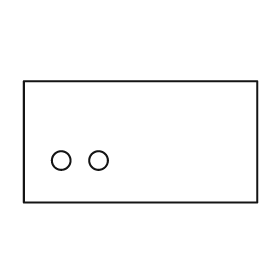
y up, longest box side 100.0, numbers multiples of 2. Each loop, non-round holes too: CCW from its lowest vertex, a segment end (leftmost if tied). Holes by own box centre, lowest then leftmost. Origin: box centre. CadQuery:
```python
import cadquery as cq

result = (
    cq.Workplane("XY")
    .moveTo(-50.0, -26.0)
    .lineTo(50.0, -26.0)
    .lineTo(50.0, 26.0)
    .lineTo(-50.0, 26.0)
    .close()
    .moveTo(-34.0, -8.0)
    .circle(4.0)
    .moveTo(-18.0, -8.0)
    .circle(4.0)
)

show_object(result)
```